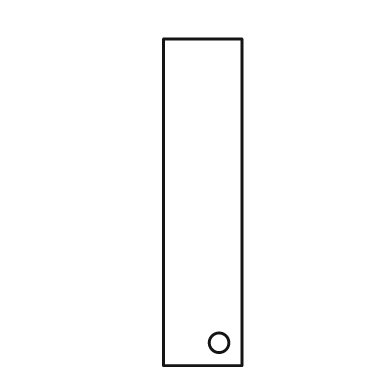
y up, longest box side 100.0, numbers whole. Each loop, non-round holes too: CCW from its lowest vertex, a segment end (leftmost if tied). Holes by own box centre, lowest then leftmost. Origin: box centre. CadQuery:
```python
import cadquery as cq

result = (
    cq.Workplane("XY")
    .moveTo(-12.0, -50.0)
    .lineTo(12.0, -50.0)
    .lineTo(12.0, 50.0)
    .lineTo(-12.0, 50.0)
    .close()
    .moveTo(5.0, -43.0)
    .circle(3.0)
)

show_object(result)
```